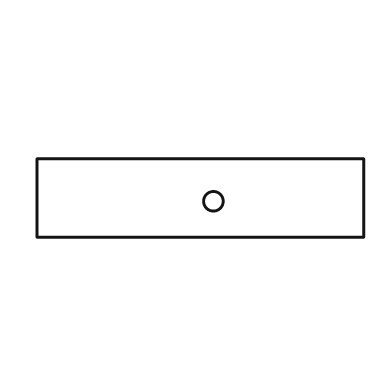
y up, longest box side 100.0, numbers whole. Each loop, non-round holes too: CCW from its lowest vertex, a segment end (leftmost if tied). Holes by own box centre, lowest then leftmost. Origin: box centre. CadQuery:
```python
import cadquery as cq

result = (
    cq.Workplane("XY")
    .moveTo(-50.0, -12.0)
    .lineTo(50.0, -12.0)
    .lineTo(50.0, 12.0)
    .lineTo(-50.0, 12.0)
    .close()
    .moveTo(4.0, -1.0)
    .circle(3.0)
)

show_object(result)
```